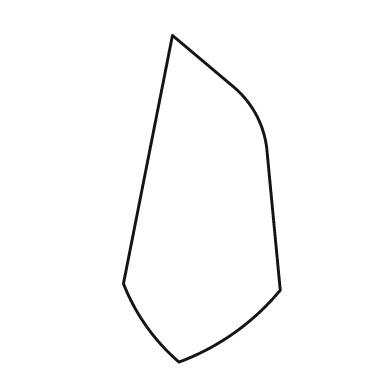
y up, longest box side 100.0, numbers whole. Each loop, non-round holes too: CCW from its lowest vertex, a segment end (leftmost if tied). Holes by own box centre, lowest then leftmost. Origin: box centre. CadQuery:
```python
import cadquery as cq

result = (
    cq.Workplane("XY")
    .moveTo(-7.0, -50.0)
    .threePointArc((10.0, -41.0), (24.0, -28.0))
    .lineTo(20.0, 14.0)
    .threePointArc((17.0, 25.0), (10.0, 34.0))
    .lineTo(-9.0, 50.0)
    .lineTo(-24.0, -26.0)
    .threePointArc((-17.0, -39.0), (-7.0, -50.0))
    .close()
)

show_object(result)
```